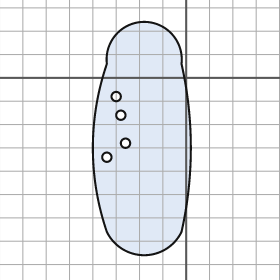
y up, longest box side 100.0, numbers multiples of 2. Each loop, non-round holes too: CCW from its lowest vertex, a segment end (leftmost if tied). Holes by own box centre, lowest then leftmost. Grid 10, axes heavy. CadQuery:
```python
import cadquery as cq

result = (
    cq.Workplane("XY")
    .moveTo(-34.0, -66.0)
    .threePointArc((-18.0, -76.0), (-2.0, -66.0))
    .threePointArc((2.0, -30.0), (-2.0, 6.0))
    .threePointArc((-18.0, 24.0), (-34.0, 6.0))
    .threePointArc((-40.0, -30.0), (-34.0, -66.0))
    .close()
    .moveTo(-34.0, -34.0)
    .circle(2.0)
    .moveTo(-26.0, -28.0)
    .circle(2.0)
    .moveTo(-28.0, -16.0)
    .circle(2.0)
    .moveTo(-30.0, -8.0)
    .circle(2.0)
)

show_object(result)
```